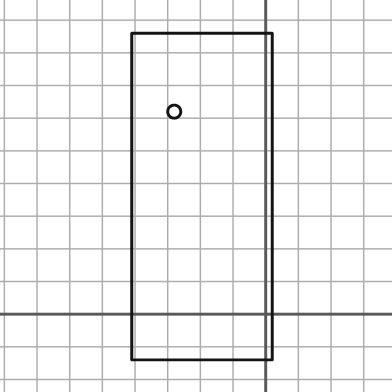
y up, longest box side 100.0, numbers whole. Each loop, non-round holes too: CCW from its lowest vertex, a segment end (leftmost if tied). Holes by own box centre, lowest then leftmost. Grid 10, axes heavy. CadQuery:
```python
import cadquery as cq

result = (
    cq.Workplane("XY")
    .moveTo(-41.0, -14.0)
    .lineTo(2.0, -14.0)
    .lineTo(2.0, 86.0)
    .lineTo(-41.0, 86.0)
    .close()
    .moveTo(-28.0, 62.0)
    .circle(2.0)
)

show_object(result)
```